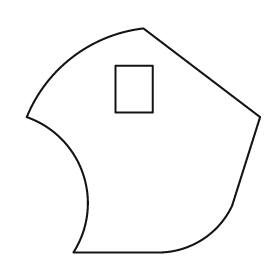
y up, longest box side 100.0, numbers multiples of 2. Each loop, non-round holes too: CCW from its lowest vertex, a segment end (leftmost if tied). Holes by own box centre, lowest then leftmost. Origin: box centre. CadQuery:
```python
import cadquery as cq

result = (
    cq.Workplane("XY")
    .moveTo(-30.0, -48.0)
    .lineTo(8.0, -48.0)
    .threePointArc((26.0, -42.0), (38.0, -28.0))
    .lineTo(50.0, 10.0)
    .lineTo(0.0, 48.0)
    .threePointArc((-30.0, 36.0), (-50.0, 10.0))
    .threePointArc((-26.0, -14.0), (-30.0, -48.0))
    .close()
    .moveTo(-12.0, 12.0)
    .lineTo(4.0, 12.0)
    .lineTo(4.0, 32.0)
    .lineTo(-12.0, 32.0)
    .close()
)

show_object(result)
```